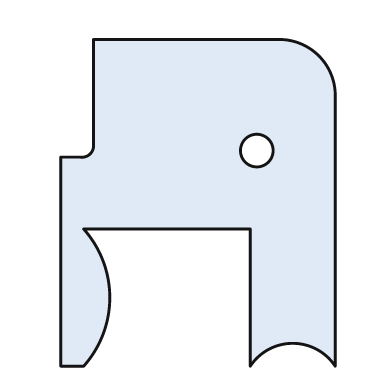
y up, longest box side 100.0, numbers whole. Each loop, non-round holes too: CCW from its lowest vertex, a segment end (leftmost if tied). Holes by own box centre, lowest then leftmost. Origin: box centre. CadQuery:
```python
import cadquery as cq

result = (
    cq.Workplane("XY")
    .moveTo(-42.0, -50.0)
    .lineTo(-35.0, -50.0)
    .threePointArc((-27.0, -29.0), (-35.0, -8.0))
    .lineTo(16.0, -8.0)
    .lineTo(16.0, -50.0)
    .threePointArc((29.0, -43.0), (42.0, -50.0))
    .lineTo(42.0, 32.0)
    .threePointArc((37.0, 45.0), (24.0, 50.0))
    .lineTo(-32.0, 50.0)
    .lineTo(-32.0, 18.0)
    .threePointArc((-33.0, 15.0), (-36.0, 14.0))
    .lineTo(-42.0, 14.0)
    .close()
    .moveTo(18.0, 16.0)
    .circle(5.0)
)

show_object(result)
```